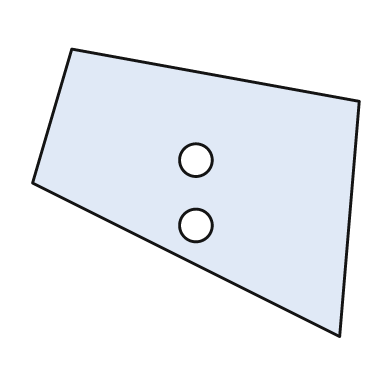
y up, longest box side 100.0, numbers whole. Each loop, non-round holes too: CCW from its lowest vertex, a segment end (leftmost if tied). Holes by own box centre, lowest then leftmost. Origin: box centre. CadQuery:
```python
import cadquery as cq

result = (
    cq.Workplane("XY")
    .moveTo(44.0, -44.0)
    .lineTo(50.0, 28.0)
    .lineTo(-38.0, 44.0)
    .lineTo(-50.0, 3.0)
    .close()
    .moveTo(0.0, -10.0)
    .circle(5.0)
    .moveTo(0.0, 10.0)
    .circle(5.0)
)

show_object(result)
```